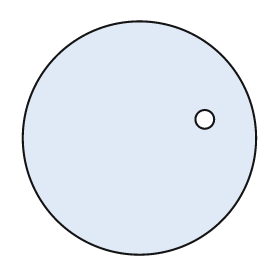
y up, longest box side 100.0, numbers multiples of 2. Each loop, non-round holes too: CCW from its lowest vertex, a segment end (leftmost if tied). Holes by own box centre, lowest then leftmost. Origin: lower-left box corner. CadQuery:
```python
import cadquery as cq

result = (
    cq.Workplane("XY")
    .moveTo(50.0, 50.0)
    .circle(50.0)
    .moveTo(78.0, 58.0)
    .circle(4.0)
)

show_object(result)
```